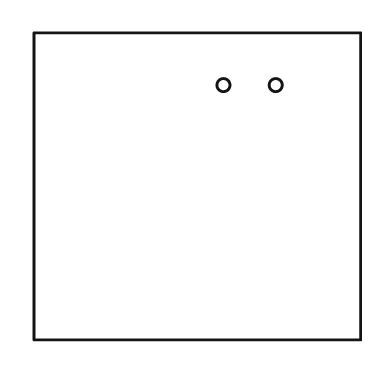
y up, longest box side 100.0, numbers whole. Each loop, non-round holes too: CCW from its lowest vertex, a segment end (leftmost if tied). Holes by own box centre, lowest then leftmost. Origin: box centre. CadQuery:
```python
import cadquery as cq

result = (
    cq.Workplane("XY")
    .moveTo(-50.0, -47.0)
    .lineTo(50.0, -47.0)
    .lineTo(50.0, 47.0)
    .lineTo(-50.0, 47.0)
    .close()
    .moveTo(8.0, 31.0)
    .circle(2.0)
    .moveTo(24.0, 31.0)
    .circle(2.0)
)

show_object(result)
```